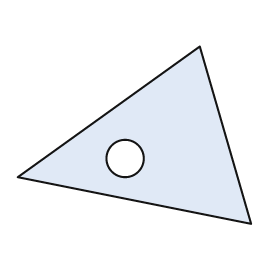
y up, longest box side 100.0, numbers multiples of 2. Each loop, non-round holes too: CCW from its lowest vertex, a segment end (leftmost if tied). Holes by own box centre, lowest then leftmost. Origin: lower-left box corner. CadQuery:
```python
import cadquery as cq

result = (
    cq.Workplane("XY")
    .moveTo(100.0, 0.0)
    .lineTo(78.0, 76.0)
    .lineTo(0.0, 20.0)
    .close()
    .moveTo(46.0, 28.0)
    .circle(8.0)
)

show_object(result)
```